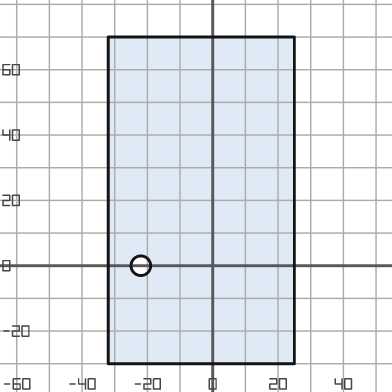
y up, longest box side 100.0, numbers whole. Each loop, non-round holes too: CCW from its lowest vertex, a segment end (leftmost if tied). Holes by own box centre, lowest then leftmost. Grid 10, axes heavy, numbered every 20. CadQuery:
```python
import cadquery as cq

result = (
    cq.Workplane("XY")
    .moveTo(-32.0, -30.0)
    .lineTo(25.0, -30.0)
    .lineTo(25.0, 70.0)
    .lineTo(-32.0, 70.0)
    .close()
    .moveTo(-22.0, 0.0)
    .circle(3.0)
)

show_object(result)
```